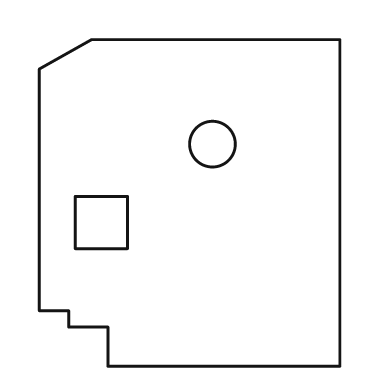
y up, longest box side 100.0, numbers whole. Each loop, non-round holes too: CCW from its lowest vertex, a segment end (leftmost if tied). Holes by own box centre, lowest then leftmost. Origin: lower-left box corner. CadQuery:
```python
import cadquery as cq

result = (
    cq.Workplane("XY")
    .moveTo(21.0, 0.0)
    .lineTo(92.0, 0.0)
    .lineTo(92.0, 100.0)
    .lineTo(16.0, 100.0)
    .lineTo(0.0, 91.0)
    .lineTo(0.0, 17.0)
    .lineTo(9.0, 17.0)
    .lineTo(9.0, 12.0)
    .lineTo(21.0, 12.0)
    .close()
    .moveTo(11.0, 36.0)
    .lineTo(27.0, 36.0)
    .lineTo(27.0, 52.0)
    .lineTo(11.0, 52.0)
    .close()
    .moveTo(53.0, 68.0)
    .circle(7.0)
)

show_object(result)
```